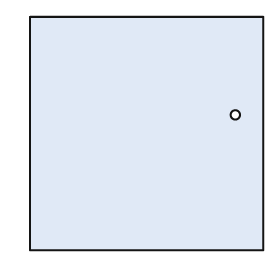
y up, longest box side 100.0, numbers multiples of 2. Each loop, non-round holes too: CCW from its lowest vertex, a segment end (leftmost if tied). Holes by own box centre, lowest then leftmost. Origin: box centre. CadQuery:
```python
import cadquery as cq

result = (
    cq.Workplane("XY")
    .moveTo(-50.0, -50.0)
    .lineTo(50.0, -50.0)
    .lineTo(50.0, 50.0)
    .lineTo(-50.0, 50.0)
    .close()
    .moveTo(38.0, 8.0)
    .circle(2.0)
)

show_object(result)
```